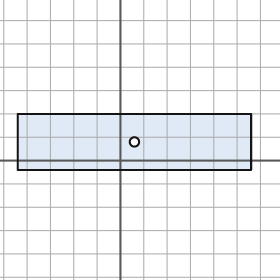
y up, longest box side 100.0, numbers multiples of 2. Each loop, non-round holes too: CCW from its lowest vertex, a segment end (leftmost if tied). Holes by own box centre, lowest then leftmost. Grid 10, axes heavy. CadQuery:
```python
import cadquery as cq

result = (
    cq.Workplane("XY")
    .moveTo(-44.0, -4.0)
    .lineTo(56.0, -4.0)
    .lineTo(56.0, 20.0)
    .lineTo(-44.0, 20.0)
    .close()
    .moveTo(6.0, 8.0)
    .circle(2.0)
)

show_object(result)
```